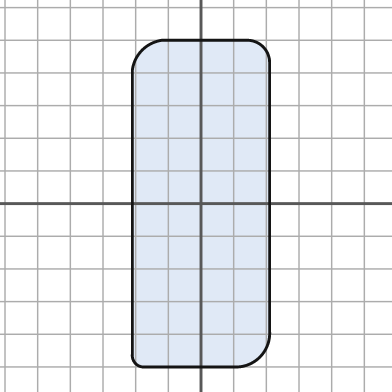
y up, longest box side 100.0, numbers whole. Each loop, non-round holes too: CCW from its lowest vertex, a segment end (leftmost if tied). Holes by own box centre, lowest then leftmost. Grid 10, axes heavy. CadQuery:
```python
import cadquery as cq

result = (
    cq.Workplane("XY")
    .moveTo(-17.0, -50.0)
    .lineTo(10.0, -50.0)
    .threePointArc((18.0, -47.0), (21.0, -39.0))
    .lineTo(21.0, 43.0)
    .threePointArc((19.0, 48.0), (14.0, 50.0))
    .lineTo(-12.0, 50.0)
    .threePointArc((-18.0, 47.0), (-21.0, 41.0))
    .lineTo(-21.0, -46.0)
    .threePointArc((-20.0, -49.0), (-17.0, -50.0))
    .close()
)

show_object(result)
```